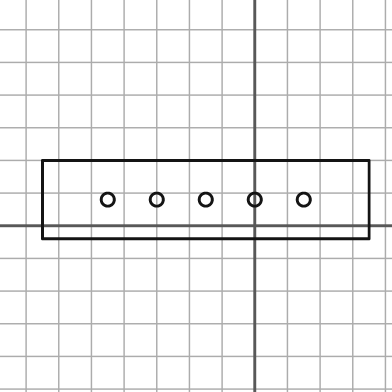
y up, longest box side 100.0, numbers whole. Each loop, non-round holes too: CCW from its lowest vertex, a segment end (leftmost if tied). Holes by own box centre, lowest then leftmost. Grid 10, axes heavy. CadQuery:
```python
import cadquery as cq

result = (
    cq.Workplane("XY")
    .moveTo(-65.0, -4.0)
    .lineTo(35.0, -4.0)
    .lineTo(35.0, 20.0)
    .lineTo(-65.0, 20.0)
    .close()
    .moveTo(-45.0, 8.0)
    .circle(2.0)
    .moveTo(-30.0, 8.0)
    .circle(2.0)
    .moveTo(-15.0, 8.0)
    .circle(2.0)
    .moveTo(0.0, 8.0)
    .circle(2.0)
    .moveTo(15.0, 8.0)
    .circle(2.0)
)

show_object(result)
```